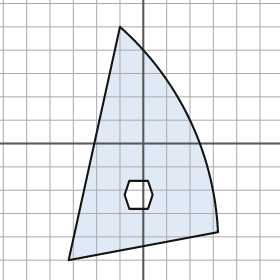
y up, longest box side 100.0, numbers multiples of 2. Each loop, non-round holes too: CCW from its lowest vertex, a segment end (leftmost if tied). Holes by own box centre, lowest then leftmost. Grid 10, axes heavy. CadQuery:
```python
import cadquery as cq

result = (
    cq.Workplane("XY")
    .moveTo(-32.0, -50.0)
    .lineTo(32.0, -38.0)
    .threePointArc((20.0, 10.0), (-10.0, 50.0))
    .close()
    .moveTo(-6.0, -28.0)
    .lineTo(2.0, -28.0)
    .lineTo(4.0, -22.0)
    .lineTo(2.0, -16.0)
    .lineTo(-6.0, -16.0)
    .lineTo(-8.0, -22.0)
    .close()
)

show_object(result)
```